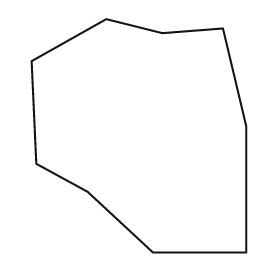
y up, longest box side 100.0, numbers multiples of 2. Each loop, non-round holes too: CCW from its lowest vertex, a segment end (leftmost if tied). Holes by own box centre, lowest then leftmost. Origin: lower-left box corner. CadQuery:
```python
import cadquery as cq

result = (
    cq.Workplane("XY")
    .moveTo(52.0, 0.0)
    .lineTo(92.0, 0.0)
    .lineTo(92.0, 54.0)
    .lineTo(82.0, 96.0)
    .lineTo(56.0, 94.0)
    .lineTo(32.0, 100.0)
    .lineTo(0.0, 82.0)
    .lineTo(2.0, 38.0)
    .lineTo(24.0, 26.0)
    .close()
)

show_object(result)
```